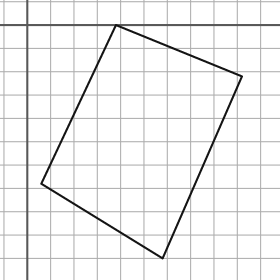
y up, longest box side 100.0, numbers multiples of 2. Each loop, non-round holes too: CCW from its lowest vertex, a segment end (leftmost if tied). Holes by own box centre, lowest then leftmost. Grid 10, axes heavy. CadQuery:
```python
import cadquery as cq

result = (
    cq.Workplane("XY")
    .moveTo(58.0, -100.0)
    .lineTo(92.0, -22.0)
    .lineTo(38.0, 0.0)
    .lineTo(6.0, -68.0)
    .close()
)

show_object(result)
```